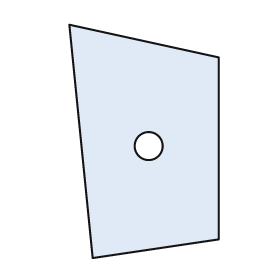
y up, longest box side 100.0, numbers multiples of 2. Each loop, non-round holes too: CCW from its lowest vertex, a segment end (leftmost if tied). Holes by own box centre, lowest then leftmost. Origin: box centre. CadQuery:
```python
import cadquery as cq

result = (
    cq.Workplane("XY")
    .moveTo(-22.0, -50.0)
    .lineTo(32.0, -42.0)
    .lineTo(32.0, 36.0)
    .lineTo(-32.0, 50.0)
    .close()
    .moveTo(2.0, -2.0)
    .circle(6.0)
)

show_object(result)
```